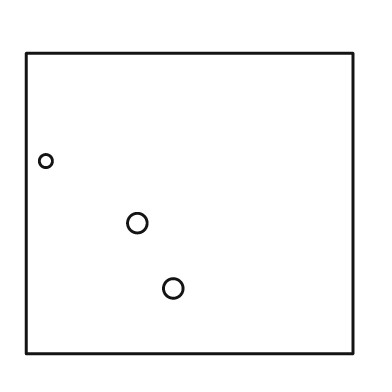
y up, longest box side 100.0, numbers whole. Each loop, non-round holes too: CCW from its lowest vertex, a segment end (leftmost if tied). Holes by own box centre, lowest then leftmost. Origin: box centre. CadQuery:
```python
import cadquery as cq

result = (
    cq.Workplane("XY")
    .moveTo(-50.0, -46.0)
    .lineTo(50.0, -46.0)
    .lineTo(50.0, 46.0)
    .lineTo(-50.0, 46.0)
    .close()
    .moveTo(-5.0, -26.0)
    .circle(3.0)
    .moveTo(-16.0, -6.0)
    .circle(3.0)
    .moveTo(-44.0, 13.0)
    .circle(2.0)
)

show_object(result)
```